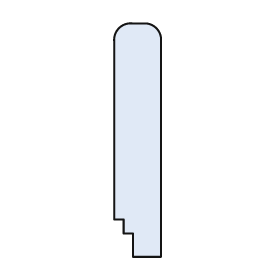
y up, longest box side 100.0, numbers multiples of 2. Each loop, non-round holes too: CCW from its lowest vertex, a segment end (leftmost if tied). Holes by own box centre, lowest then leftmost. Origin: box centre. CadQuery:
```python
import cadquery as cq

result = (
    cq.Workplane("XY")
    .moveTo(-2.0, -50.0)
    .lineTo(10.0, -50.0)
    .lineTo(10.0, 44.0)
    .threePointArc((8.0, 48.0), (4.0, 50.0))
    .lineTo(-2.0, 50.0)
    .threePointArc((-8.0, 48.0), (-10.0, 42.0))
    .lineTo(-10.0, -34.0)
    .lineTo(-6.0, -34.0)
    .lineTo(-6.0, -40.0)
    .lineTo(-2.0, -40.0)
    .close()
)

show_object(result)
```